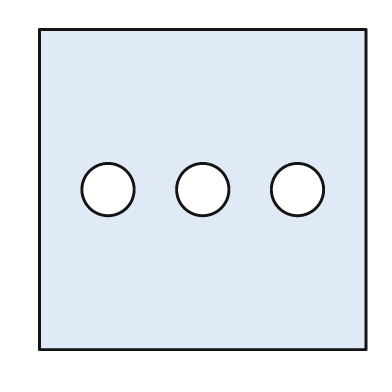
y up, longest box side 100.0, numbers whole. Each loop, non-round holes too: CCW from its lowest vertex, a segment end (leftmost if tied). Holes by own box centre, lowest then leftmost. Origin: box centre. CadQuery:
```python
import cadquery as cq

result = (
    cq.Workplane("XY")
    .moveTo(-50.0, -49.0)
    .lineTo(50.0, -49.0)
    .lineTo(50.0, 49.0)
    .lineTo(-50.0, 49.0)
    .close()
    .moveTo(-29.0, 0.0)
    .circle(8.0)
    .moveTo(0.0, 0.0)
    .circle(8.0)
    .moveTo(29.0, 0.0)
    .circle(8.0)
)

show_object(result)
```